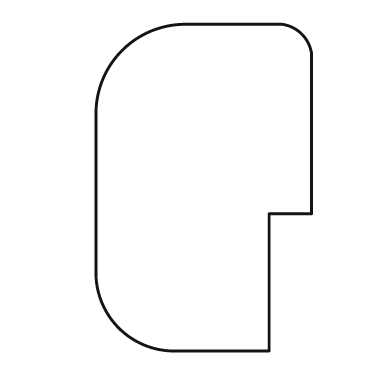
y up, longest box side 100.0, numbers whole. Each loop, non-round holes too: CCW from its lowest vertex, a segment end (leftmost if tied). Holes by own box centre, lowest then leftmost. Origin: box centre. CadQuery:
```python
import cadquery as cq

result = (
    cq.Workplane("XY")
    .moveTo(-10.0, -50.0)
    .lineTo(20.0, -50.0)
    .lineTo(20.0, -8.0)
    .lineTo(33.0, -8.0)
    .lineTo(33.0, 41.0)
    .threePointArc((30.0, 47.0), (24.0, 50.0))
    .lineTo(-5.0, 50.0)
    .threePointArc((-25.0, 42.0), (-33.0, 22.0))
    .lineTo(-33.0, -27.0)
    .threePointArc((-26.0, -43.0), (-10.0, -50.0))
    .close()
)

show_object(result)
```